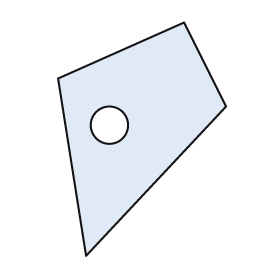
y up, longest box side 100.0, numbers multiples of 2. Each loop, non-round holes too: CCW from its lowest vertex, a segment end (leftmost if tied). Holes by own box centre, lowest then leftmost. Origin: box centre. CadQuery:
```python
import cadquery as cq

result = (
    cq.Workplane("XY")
    .moveTo(-24.0, -50.0)
    .lineTo(36.0, 14.0)
    .lineTo(18.0, 50.0)
    .lineTo(-36.0, 26.0)
    .close()
    .moveTo(-14.0, 6.0)
    .circle(8.0)
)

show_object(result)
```